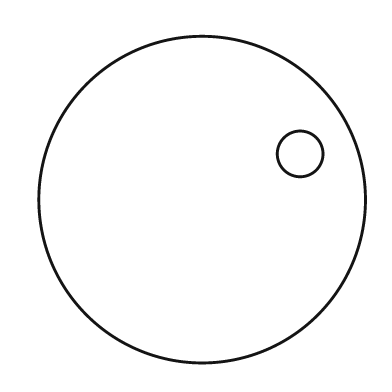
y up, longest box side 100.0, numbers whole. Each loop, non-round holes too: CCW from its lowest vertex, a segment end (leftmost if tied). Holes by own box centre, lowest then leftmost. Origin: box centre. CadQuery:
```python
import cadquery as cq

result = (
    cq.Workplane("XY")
    .moveTo(0.0, 0.0)
    .circle(50.0)
    .moveTo(30.0, 14.0)
    .circle(7.0)
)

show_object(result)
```